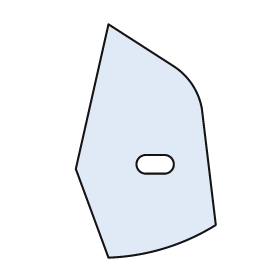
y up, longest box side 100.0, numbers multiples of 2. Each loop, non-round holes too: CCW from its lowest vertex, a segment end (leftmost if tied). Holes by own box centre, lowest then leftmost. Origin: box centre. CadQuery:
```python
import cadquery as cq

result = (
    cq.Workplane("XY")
    .moveTo(-16.0, -50.0)
    .threePointArc((8.0, -46.0), (30.0, -36.0))
    .lineTo(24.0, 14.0)
    .threePointArc((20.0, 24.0), (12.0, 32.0))
    .lineTo(-16.0, 50.0)
    .lineTo(-30.0, -12.0)
    .close()
    .moveTo(0.0, -14.0)
    .lineTo(8.0, -14.0)
    .threePointArc((12.0, -10.0), (8.0, -6.0))
    .lineTo(0.0, -6.0)
    .threePointArc((-4.0, -10.0), (0.0, -14.0))
    .close()
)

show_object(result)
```